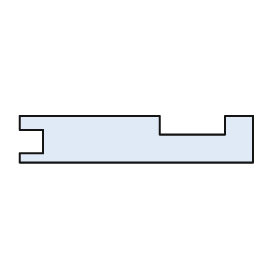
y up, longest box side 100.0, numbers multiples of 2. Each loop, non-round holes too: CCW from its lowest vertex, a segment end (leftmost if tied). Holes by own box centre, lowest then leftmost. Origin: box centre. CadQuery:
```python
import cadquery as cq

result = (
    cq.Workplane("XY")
    .moveTo(-50.0, -10.0)
    .lineTo(50.0, -10.0)
    .lineTo(50.0, 10.0)
    .lineTo(38.0, 10.0)
    .lineTo(38.0, 2.0)
    .lineTo(10.0, 2.0)
    .lineTo(10.0, 10.0)
    .lineTo(-50.0, 10.0)
    .lineTo(-50.0, 4.0)
    .lineTo(-40.0, 4.0)
    .lineTo(-40.0, -6.0)
    .lineTo(-50.0, -6.0)
    .close()
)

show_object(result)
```